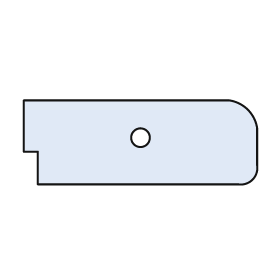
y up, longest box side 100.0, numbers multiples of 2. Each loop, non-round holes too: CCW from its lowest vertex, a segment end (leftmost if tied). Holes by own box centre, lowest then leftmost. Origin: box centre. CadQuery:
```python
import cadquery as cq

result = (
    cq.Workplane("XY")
    .moveTo(-44.0, -18.0)
    .lineTo(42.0, -18.0)
    .threePointArc((48.0, -16.0), (50.0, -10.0))
    .lineTo(50.0, 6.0)
    .threePointArc((46.0, 14.0), (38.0, 18.0))
    .lineTo(-50.0, 18.0)
    .lineTo(-50.0, -4.0)
    .lineTo(-44.0, -4.0)
    .close()
    .moveTo(0.0, 2.0)
    .circle(4.0)
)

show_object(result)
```